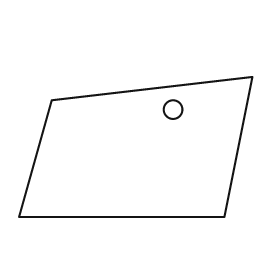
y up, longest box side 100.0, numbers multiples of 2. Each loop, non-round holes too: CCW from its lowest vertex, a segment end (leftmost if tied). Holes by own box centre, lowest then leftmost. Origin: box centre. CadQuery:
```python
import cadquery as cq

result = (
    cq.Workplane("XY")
    .moveTo(-50.0, -30.0)
    .lineTo(38.0, -30.0)
    .lineTo(50.0, 30.0)
    .lineTo(-36.0, 20.0)
    .close()
    .moveTo(16.0, 16.0)
    .circle(4.0)
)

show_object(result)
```